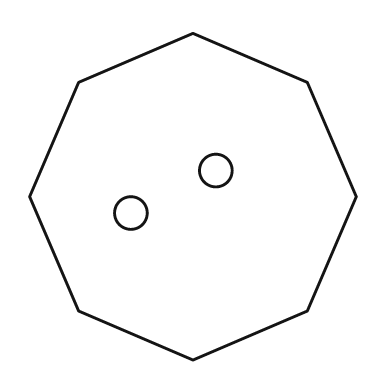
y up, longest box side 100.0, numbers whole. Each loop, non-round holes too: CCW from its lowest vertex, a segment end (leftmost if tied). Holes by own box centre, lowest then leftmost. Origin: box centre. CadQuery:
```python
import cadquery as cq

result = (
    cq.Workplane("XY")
    .moveTo(0.0, -50.0)
    .lineTo(35.0, -35.0)
    .lineTo(50.0, 0.0)
    .lineTo(35.0, 35.0)
    .lineTo(0.0, 50.0)
    .lineTo(-35.0, 35.0)
    .lineTo(-50.0, 0.0)
    .lineTo(-35.0, -35.0)
    .close()
    .moveTo(-19.0, -5.0)
    .circle(5.0)
    .moveTo(7.0, 8.0)
    .circle(5.0)
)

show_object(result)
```